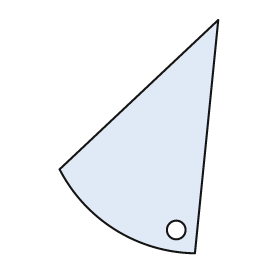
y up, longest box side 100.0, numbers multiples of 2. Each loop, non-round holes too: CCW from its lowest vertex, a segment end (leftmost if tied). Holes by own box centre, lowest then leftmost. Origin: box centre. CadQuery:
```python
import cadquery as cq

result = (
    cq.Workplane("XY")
    .moveTo(24.0, -50.0)
    .lineTo(34.0, 50.0)
    .lineTo(-34.0, -14.0)
    .threePointArc((-10.0, -40.0), (24.0, -50.0))
    .close()
    .moveTo(16.0, -40.0)
    .circle(4.0)
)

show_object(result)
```